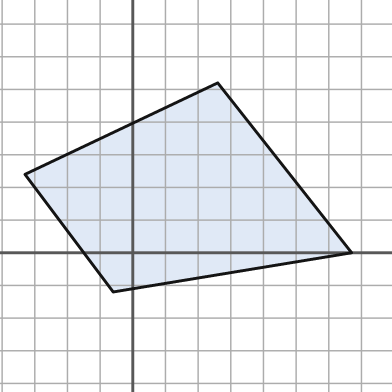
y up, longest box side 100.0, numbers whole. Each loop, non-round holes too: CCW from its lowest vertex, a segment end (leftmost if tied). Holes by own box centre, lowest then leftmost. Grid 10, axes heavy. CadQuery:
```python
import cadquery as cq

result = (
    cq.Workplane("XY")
    .moveTo(-6.0, -12.0)
    .lineTo(67.0, 0.0)
    .lineTo(26.0, 52.0)
    .lineTo(-33.0, 24.0)
    .close()
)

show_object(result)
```